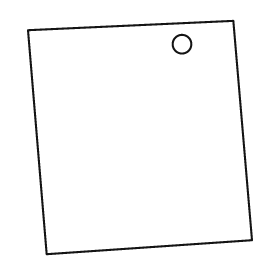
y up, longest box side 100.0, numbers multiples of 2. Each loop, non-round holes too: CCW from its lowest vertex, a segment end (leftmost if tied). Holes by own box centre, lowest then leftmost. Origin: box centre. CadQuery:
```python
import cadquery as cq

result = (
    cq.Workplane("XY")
    .moveTo(-40.0, -50.0)
    .lineTo(48.0, -44.0)
    .lineTo(40.0, 50.0)
    .lineTo(-48.0, 46.0)
    .close()
    .moveTo(18.0, 40.0)
    .circle(4.0)
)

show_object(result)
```